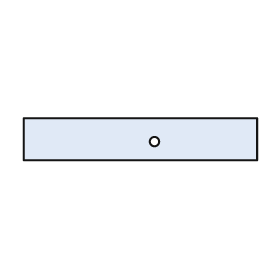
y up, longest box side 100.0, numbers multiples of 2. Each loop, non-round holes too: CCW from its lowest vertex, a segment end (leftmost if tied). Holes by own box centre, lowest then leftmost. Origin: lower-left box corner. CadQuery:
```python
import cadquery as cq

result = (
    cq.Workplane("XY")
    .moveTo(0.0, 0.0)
    .lineTo(100.0, 0.0)
    .lineTo(100.0, 18.0)
    .lineTo(0.0, 18.0)
    .close()
    .moveTo(56.0, 8.0)
    .circle(2.0)
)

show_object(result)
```